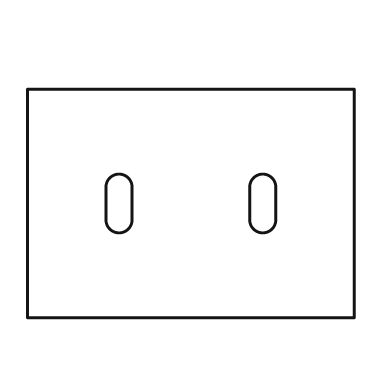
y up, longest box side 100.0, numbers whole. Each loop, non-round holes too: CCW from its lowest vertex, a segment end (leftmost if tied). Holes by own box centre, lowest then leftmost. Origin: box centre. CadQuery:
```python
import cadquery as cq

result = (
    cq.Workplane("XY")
    .moveTo(-50.0, -35.0)
    .lineTo(50.0, -35.0)
    .lineTo(50.0, 35.0)
    .lineTo(-50.0, 35.0)
    .close()
    .moveTo(-26.0, -5.0)
    .threePointArc((-22.0, -9.0), (-18.0, -5.0))
    .lineTo(-18.0, 5.0)
    .threePointArc((-22.0, 9.0), (-26.0, 5.0))
    .close()
    .moveTo(18.0, -5.0)
    .threePointArc((22.0, -9.0), (26.0, -5.0))
    .lineTo(26.0, 5.0)
    .threePointArc((22.0, 9.0), (18.0, 5.0))
    .close()
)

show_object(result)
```